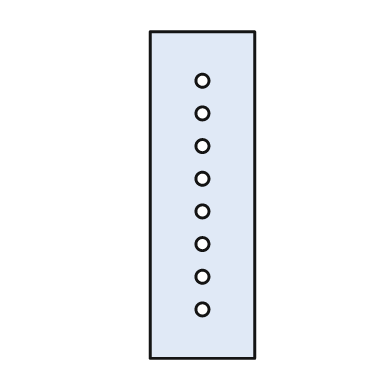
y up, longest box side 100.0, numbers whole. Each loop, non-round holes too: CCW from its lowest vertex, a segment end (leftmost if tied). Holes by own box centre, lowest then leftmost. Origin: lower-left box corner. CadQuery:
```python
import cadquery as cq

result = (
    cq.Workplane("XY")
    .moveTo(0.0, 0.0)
    .lineTo(32.0, 0.0)
    .lineTo(32.0, 100.0)
    .lineTo(0.0, 100.0)
    .close()
    .moveTo(16.0, 15.0)
    .circle(2.0)
    .moveTo(16.0, 25.0)
    .circle(2.0)
    .moveTo(16.0, 35.0)
    .circle(2.0)
    .moveTo(16.0, 45.0)
    .circle(2.0)
    .moveTo(16.0, 55.0)
    .circle(2.0)
    .moveTo(16.0, 65.0)
    .circle(2.0)
    .moveTo(16.0, 75.0)
    .circle(2.0)
    .moveTo(16.0, 85.0)
    .circle(2.0)
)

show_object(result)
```